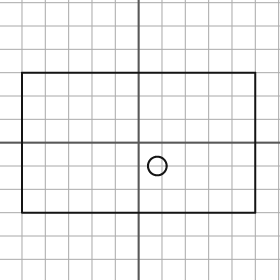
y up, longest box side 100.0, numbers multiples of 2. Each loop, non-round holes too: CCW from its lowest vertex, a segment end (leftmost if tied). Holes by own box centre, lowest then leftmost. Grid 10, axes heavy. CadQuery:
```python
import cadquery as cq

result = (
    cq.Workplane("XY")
    .moveTo(-50.0, -30.0)
    .lineTo(50.0, -30.0)
    .lineTo(50.0, 30.0)
    .lineTo(-50.0, 30.0)
    .close()
    .moveTo(8.0, -10.0)
    .circle(4.0)
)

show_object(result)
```